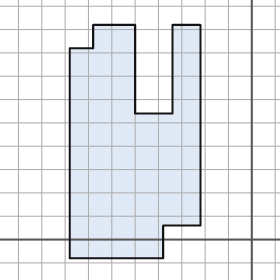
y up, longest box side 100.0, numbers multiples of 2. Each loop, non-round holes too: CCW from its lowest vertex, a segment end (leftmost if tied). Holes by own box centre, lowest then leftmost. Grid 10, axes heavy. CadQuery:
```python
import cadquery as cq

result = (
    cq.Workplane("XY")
    .moveTo(-78.0, -8.0)
    .lineTo(-38.0, -8.0)
    .lineTo(-38.0, 6.0)
    .lineTo(-22.0, 6.0)
    .lineTo(-22.0, 92.0)
    .lineTo(-34.0, 92.0)
    .lineTo(-34.0, 54.0)
    .lineTo(-50.0, 54.0)
    .lineTo(-50.0, 92.0)
    .lineTo(-68.0, 92.0)
    .lineTo(-68.0, 82.0)
    .lineTo(-78.0, 82.0)
    .close()
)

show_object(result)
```